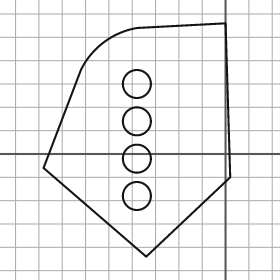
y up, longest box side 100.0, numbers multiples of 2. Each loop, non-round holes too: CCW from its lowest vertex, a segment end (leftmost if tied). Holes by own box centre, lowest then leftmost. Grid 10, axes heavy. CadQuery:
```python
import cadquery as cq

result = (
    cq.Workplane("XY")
    .moveTo(-34.0, -44.0)
    .lineTo(2.0, -10.0)
    .lineTo(0.0, 56.0)
    .lineTo(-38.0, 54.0)
    .threePointArc((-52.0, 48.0), (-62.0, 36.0))
    .lineTo(-78.0, -6.0)
    .close()
    .moveTo(-38.0, -18.0)
    .circle(6.0)
    .moveTo(-38.0, -2.0)
    .circle(6.0)
    .moveTo(-38.0, 14.0)
    .circle(6.0)
    .moveTo(-38.0, 30.0)
    .circle(6.0)
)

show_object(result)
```